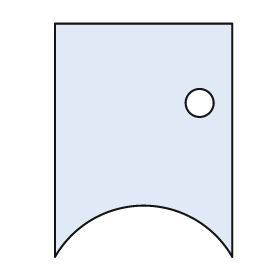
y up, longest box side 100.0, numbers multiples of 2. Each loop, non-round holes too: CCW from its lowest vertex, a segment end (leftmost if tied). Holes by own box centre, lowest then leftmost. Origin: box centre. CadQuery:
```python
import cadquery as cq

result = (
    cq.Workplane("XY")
    .moveTo(-38.0, -50.0)
    .threePointArc((0.0, -28.0), (38.0, -50.0))
    .lineTo(38.0, 50.0)
    .lineTo(-38.0, 50.0)
    .close()
    .moveTo(24.0, 16.0)
    .circle(6.0)
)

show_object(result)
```